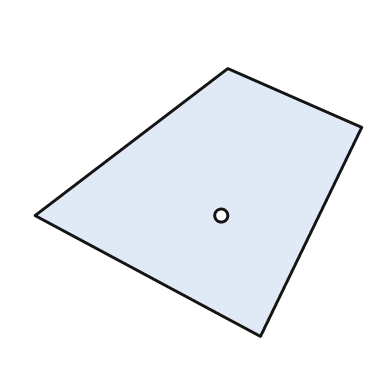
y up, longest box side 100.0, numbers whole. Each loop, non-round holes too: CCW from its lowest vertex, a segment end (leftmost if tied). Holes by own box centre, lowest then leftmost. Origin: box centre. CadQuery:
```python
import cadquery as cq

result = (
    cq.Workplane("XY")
    .moveTo(19.0, -41.0)
    .lineTo(50.0, 23.0)
    .lineTo(9.0, 41.0)
    .lineTo(-50.0, -4.0)
    .close()
    .moveTo(7.0, -4.0)
    .circle(2.0)
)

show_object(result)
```